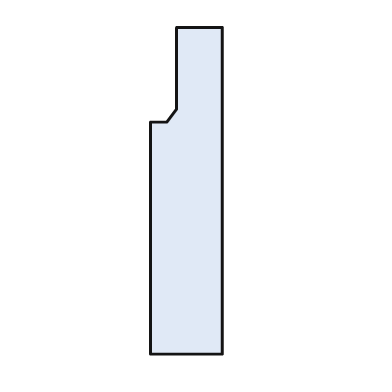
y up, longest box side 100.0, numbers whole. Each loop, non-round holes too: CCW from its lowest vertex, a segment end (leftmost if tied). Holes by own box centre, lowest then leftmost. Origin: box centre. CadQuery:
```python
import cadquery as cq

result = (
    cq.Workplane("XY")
    .moveTo(-11.0, -50.0)
    .lineTo(11.0, -50.0)
    .lineTo(11.0, 50.0)
    .lineTo(-3.0, 50.0)
    .lineTo(-3.0, 25.0)
    .lineTo(-6.0, 21.0)
    .lineTo(-11.0, 21.0)
    .close()
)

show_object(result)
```